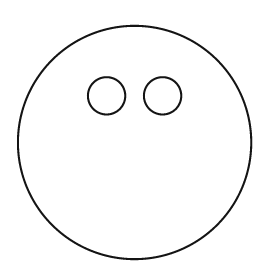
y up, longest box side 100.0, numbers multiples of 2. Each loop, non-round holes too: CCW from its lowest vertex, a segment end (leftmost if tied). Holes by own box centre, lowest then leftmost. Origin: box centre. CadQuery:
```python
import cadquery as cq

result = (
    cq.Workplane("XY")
    .moveTo(0.0, 0.0)
    .circle(50.0)
    .moveTo(-12.0, 20.0)
    .circle(8.0)
    .moveTo(12.0, 20.0)
    .circle(8.0)
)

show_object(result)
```